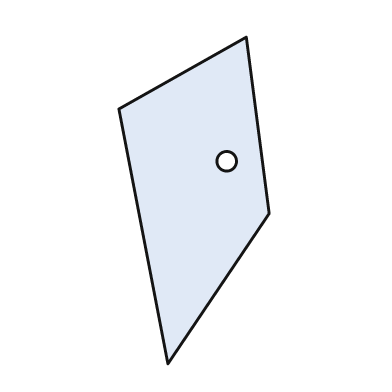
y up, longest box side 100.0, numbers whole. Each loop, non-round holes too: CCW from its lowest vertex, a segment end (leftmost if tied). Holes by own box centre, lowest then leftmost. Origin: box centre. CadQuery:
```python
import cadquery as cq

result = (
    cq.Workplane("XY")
    .moveTo(-8.0, -50.0)
    .lineTo(23.0, -4.0)
    .lineTo(16.0, 50.0)
    .lineTo(-23.0, 28.0)
    .close()
    .moveTo(10.0, 12.0)
    .circle(3.0)
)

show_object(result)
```